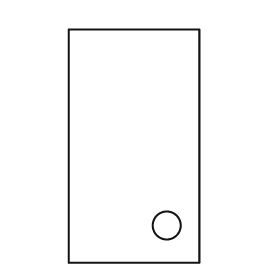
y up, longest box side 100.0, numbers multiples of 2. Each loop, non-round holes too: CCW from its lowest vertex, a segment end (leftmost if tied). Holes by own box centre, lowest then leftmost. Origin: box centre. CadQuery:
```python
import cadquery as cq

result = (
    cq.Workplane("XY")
    .moveTo(-28.0, -50.0)
    .lineTo(28.0, -50.0)
    .lineTo(28.0, 50.0)
    .lineTo(-28.0, 50.0)
    .close()
    .moveTo(14.0, -34.0)
    .circle(6.0)
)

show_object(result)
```